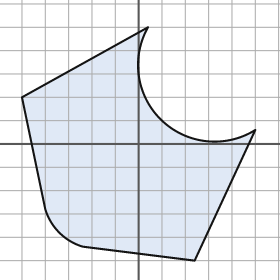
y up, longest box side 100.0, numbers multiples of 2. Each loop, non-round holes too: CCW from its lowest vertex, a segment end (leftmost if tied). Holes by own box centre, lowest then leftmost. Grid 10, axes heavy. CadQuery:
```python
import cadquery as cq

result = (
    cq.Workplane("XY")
    .moveTo(24.0, -50.0)
    .lineTo(50.0, 6.0)
    .threePointArc((10.0, 10.0), (4.0, 50.0))
    .lineTo(-50.0, 20.0)
    .lineTo(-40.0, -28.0)
    .threePointArc((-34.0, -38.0), (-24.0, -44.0))
    .close()
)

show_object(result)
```